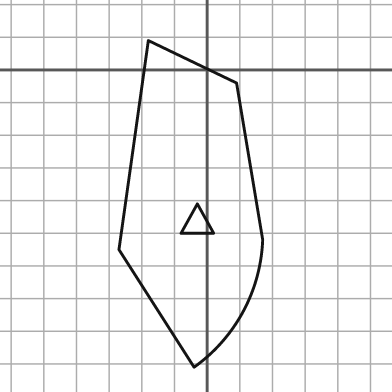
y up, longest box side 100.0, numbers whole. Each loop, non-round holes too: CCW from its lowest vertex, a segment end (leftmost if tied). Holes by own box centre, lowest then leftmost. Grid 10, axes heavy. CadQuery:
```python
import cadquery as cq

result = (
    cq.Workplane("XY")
    .moveTo(-4.0, -91.0)
    .threePointArc((11.0, -74.0), (17.0, -52.0))
    .lineTo(9.0, -4.0)
    .lineTo(-18.0, 9.0)
    .lineTo(-27.0, -55.0)
    .close()
    .moveTo(-8.0, -50.0)
    .lineTo(2.0, -50.0)
    .lineTo(-3.0, -41.0)
    .close()
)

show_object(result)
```